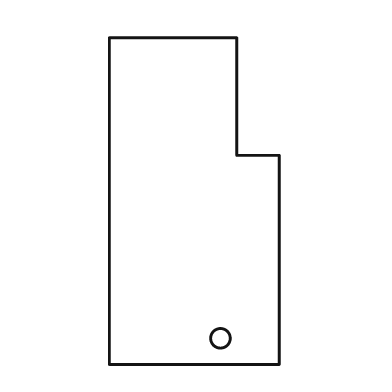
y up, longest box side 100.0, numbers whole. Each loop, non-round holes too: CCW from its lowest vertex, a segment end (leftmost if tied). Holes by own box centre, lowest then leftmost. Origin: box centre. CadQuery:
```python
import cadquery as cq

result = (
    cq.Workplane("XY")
    .moveTo(-26.0, -50.0)
    .lineTo(26.0, -50.0)
    .lineTo(26.0, 14.0)
    .lineTo(13.0, 14.0)
    .lineTo(13.0, 50.0)
    .lineTo(-26.0, 50.0)
    .close()
    .moveTo(8.0, -42.0)
    .circle(3.0)
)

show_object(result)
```